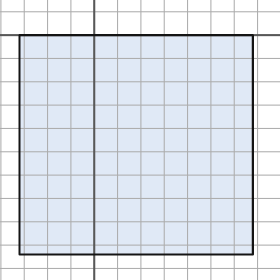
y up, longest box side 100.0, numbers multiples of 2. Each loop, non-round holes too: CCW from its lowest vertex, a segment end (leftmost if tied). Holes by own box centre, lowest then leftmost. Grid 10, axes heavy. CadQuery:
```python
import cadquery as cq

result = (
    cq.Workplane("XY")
    .moveTo(-32.0, -94.0)
    .lineTo(68.0, -94.0)
    .lineTo(68.0, 0.0)
    .lineTo(-32.0, 0.0)
    .close()
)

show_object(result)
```